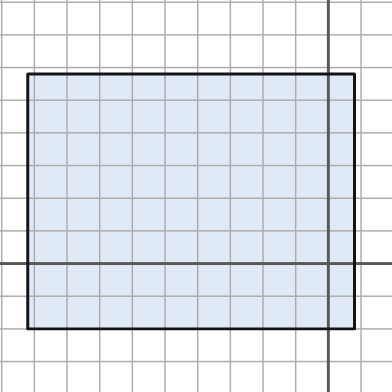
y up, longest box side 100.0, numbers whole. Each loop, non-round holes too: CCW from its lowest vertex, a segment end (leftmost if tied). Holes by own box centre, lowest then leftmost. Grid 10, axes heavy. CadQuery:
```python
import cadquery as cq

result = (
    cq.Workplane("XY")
    .moveTo(-92.0, -20.0)
    .lineTo(8.0, -20.0)
    .lineTo(8.0, 58.0)
    .lineTo(-92.0, 58.0)
    .close()
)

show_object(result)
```